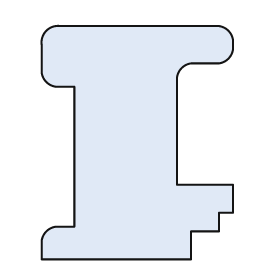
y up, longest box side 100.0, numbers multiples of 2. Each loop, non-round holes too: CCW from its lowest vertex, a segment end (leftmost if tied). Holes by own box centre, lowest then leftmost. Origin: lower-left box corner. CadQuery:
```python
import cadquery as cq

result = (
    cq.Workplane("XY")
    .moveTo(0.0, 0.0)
    .lineTo(64.0, 0.0)
    .lineTo(64.0, 12.0)
    .lineTo(76.0, 12.0)
    .lineTo(76.0, 20.0)
    .lineTo(82.0, 20.0)
    .lineTo(82.0, 32.0)
    .lineTo(58.0, 32.0)
    .lineTo(58.0, 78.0)
    .threePointArc((60.0, 82.0), (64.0, 84.0))
    .lineTo(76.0, 84.0)
    .threePointArc((80.0, 86.0), (82.0, 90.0))
    .lineTo(82.0, 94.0)
    .threePointArc((80.0, 98.0), (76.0, 100.0))
    .lineTo(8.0, 100.0)
    .threePointArc((2.0, 98.0), (0.0, 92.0))
    .lineTo(0.0, 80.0)
    .threePointArc((2.0, 76.0), (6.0, 74.0))
    .lineTo(14.0, 74.0)
    .lineTo(14.0, 14.0)
    .lineTo(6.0, 14.0)
    .threePointArc((2.0, 12.0), (0.0, 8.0))
    .close()
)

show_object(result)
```